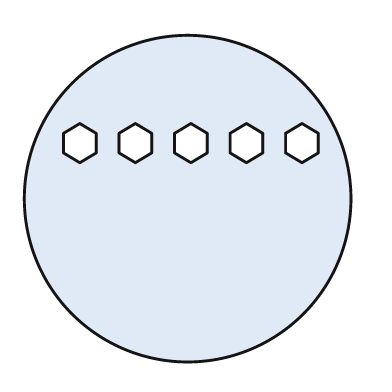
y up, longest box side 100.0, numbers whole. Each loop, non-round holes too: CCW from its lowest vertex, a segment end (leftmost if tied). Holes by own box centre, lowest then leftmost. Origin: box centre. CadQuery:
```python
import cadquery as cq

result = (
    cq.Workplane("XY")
    .moveTo(0.0, 0.0)
    .circle(50.0)
    .moveTo(-33.0, 11.0)
    .lineTo(-28.0, 14.0)
    .lineTo(-28.0, 20.0)
    .lineTo(-33.0, 23.0)
    .lineTo(-38.0, 20.0)
    .lineTo(-38.0, 14.0)
    .close()
    .moveTo(-16.0, 11.0)
    .lineTo(-11.0, 14.0)
    .lineTo(-11.0, 20.0)
    .lineTo(-16.0, 23.0)
    .lineTo(-21.0, 20.0)
    .lineTo(-21.0, 14.0)
    .close()
    .moveTo(1.0, 11.0)
    .lineTo(6.0, 14.0)
    .lineTo(6.0, 20.0)
    .lineTo(1.0, 23.0)
    .lineTo(-4.0, 20.0)
    .lineTo(-4.0, 14.0)
    .close()
    .moveTo(18.0, 11.0)
    .lineTo(23.0, 14.0)
    .lineTo(23.0, 20.0)
    .lineTo(18.0, 23.0)
    .lineTo(13.0, 20.0)
    .lineTo(13.0, 14.0)
    .close()
    .moveTo(35.0, 11.0)
    .lineTo(40.0, 14.0)
    .lineTo(40.0, 20.0)
    .lineTo(35.0, 23.0)
    .lineTo(30.0, 20.0)
    .lineTo(30.0, 14.0)
    .close()
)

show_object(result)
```